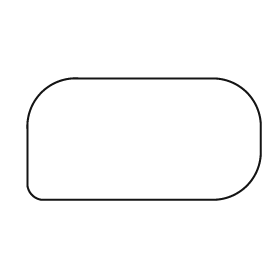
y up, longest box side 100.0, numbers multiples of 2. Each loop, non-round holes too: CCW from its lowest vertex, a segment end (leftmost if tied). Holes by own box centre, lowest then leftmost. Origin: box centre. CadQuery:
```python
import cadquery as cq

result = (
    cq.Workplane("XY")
    .moveTo(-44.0, -26.0)
    .lineTo(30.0, -26.0)
    .threePointArc((44.0, -20.0), (50.0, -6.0))
    .lineTo(50.0, 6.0)
    .threePointArc((44.0, 20.0), (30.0, 26.0))
    .lineTo(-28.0, 26.0)
    .threePointArc((-44.0, 20.0), (-50.0, 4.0))
    .lineTo(-50.0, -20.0)
    .threePointArc((-48.0, -24.0), (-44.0, -26.0))
    .close()
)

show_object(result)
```